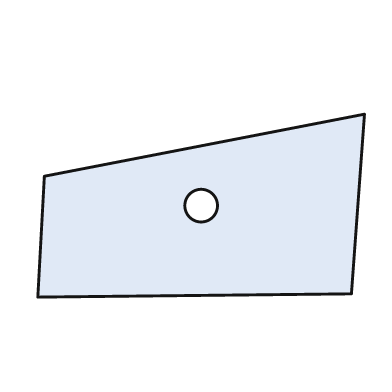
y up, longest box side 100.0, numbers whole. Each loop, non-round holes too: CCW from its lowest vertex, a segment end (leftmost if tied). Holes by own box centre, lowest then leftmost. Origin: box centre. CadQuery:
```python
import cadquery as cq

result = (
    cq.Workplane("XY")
    .moveTo(-50.0, -28.0)
    .lineTo(46.0, -27.0)
    .lineTo(50.0, 28.0)
    .lineTo(-48.0, 9.0)
    .close()
    .moveTo(0.0, 0.0)
    .circle(5.0)
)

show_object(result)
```